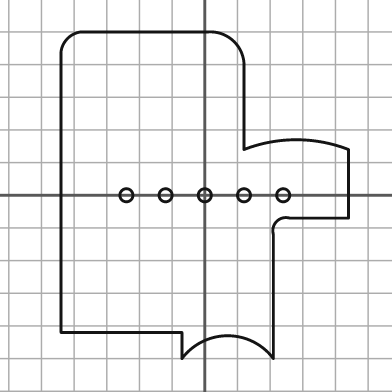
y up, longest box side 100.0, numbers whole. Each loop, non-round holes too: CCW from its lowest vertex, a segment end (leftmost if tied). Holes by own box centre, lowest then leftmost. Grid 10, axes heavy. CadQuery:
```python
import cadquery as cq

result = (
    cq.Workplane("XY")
    .moveTo(-7.0, -50.0)
    .threePointArc((7.0, -43.0), (21.0, -50.0))
    .lineTo(21.0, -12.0)
    .threePointArc((22.0, -8.0), (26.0, -7.0))
    .lineTo(44.0, -7.0)
    .lineTo(44.0, 14.0)
    .threePointArc((28.0, 17.0), (12.0, 14.0))
    .lineTo(12.0, 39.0)
    .threePointArc((9.0, 47.0), (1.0, 50.0))
    .lineTo(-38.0, 50.0)
    .threePointArc((-42.0, 48.0), (-44.0, 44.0))
    .lineTo(-44.0, -42.0)
    .lineTo(-7.0, -42.0)
    .close()
    .moveTo(-24.0, 0.0)
    .circle(2.0)
    .moveTo(-12.0, 0.0)
    .circle(2.0)
    .moveTo(0.0, 0.0)
    .circle(2.0)
    .moveTo(12.0, 0.0)
    .circle(2.0)
    .moveTo(24.0, 0.0)
    .circle(2.0)
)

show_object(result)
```